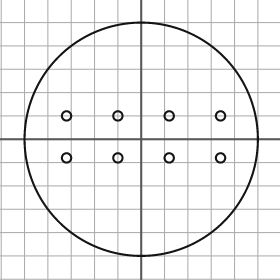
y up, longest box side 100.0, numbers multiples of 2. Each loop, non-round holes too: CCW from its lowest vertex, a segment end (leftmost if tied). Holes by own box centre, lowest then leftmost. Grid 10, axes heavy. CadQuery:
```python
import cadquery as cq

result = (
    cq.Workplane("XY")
    .moveTo(0.0, 0.0)
    .circle(50.0)
    .moveTo(-32.0, -8.0)
    .circle(2.0)
    .moveTo(-10.0, -8.0)
    .circle(2.0)
    .moveTo(12.0, -8.0)
    .circle(2.0)
    .moveTo(34.0, -8.0)
    .circle(2.0)
    .moveTo(-32.0, 10.0)
    .circle(2.0)
    .moveTo(-10.0, 10.0)
    .circle(2.0)
    .moveTo(12.0, 10.0)
    .circle(2.0)
    .moveTo(34.0, 10.0)
    .circle(2.0)
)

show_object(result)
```